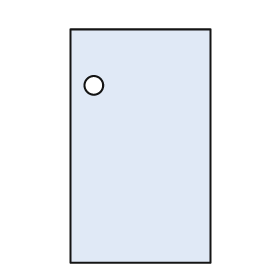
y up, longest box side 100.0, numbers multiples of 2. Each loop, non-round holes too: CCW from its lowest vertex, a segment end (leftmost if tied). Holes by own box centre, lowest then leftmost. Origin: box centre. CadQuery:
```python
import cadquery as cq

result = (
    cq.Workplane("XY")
    .moveTo(-30.0, -50.0)
    .lineTo(30.0, -50.0)
    .lineTo(30.0, 50.0)
    .lineTo(-30.0, 50.0)
    .close()
    .moveTo(-20.0, 26.0)
    .circle(4.0)
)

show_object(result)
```